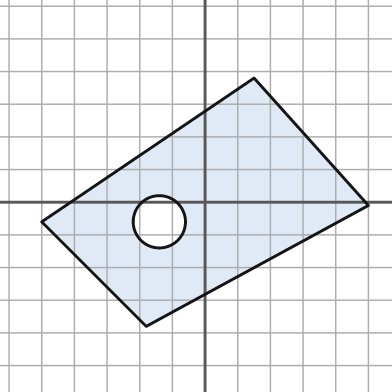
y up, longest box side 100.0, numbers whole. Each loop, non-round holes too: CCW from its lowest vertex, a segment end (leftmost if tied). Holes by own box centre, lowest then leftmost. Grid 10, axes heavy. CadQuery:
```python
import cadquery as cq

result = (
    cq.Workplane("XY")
    .moveTo(-18.0, -38.0)
    .lineTo(50.0, -1.0)
    .lineTo(15.0, 38.0)
    .lineTo(-50.0, -6.0)
    .close()
    .moveTo(-14.0, -6.0)
    .circle(8.0)
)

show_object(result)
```